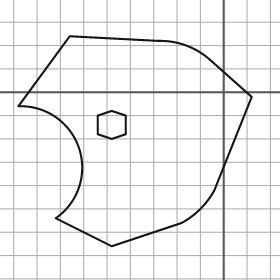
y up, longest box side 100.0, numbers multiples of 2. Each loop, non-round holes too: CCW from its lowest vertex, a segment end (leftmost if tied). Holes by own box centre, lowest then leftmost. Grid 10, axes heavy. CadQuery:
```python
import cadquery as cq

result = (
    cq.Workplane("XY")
    .moveTo(-48.0, -66.0)
    .lineTo(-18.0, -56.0)
    .threePointArc((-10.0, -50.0), (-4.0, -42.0))
    .lineTo(12.0, -2.0)
    .lineTo(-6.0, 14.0)
    .threePointArc((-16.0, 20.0), (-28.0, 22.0))
    .lineTo(-66.0, 24.0)
    .lineTo(-88.0, -6.0)
    .threePointArc((-62.0, -24.0), (-72.0, -54.0))
    .close()
    .moveTo(-48.0, -20.0)
    .lineTo(-42.0, -18.0)
    .lineTo(-42.0, -10.0)
    .lineTo(-48.0, -8.0)
    .lineTo(-54.0, -10.0)
    .lineTo(-54.0, -18.0)
    .close()
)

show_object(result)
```